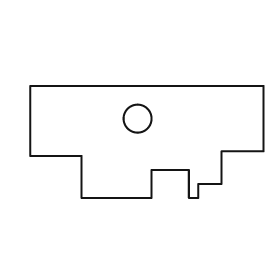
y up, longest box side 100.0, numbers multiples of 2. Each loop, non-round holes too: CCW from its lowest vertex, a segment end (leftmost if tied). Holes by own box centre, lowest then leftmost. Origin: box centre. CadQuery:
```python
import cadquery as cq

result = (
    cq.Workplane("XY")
    .moveTo(-28.0, -24.0)
    .lineTo(2.0, -24.0)
    .lineTo(2.0, -12.0)
    .lineTo(18.0, -12.0)
    .lineTo(18.0, -24.0)
    .lineTo(22.0, -24.0)
    .lineTo(22.0, -18.0)
    .lineTo(32.0, -18.0)
    .lineTo(32.0, -4.0)
    .lineTo(50.0, -4.0)
    .lineTo(50.0, 24.0)
    .lineTo(-50.0, 24.0)
    .lineTo(-50.0, -6.0)
    .lineTo(-28.0, -6.0)
    .close()
    .moveTo(-4.0, 10.0)
    .circle(6.0)
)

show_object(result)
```